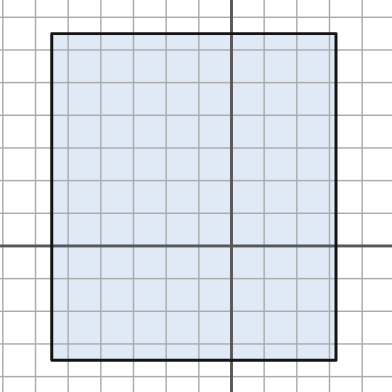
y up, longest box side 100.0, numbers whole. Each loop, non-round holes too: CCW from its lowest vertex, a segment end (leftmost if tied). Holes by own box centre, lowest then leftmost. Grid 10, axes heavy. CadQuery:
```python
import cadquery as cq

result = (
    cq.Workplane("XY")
    .moveTo(-55.0, -35.0)
    .lineTo(32.0, -35.0)
    .lineTo(32.0, 65.0)
    .lineTo(-55.0, 65.0)
    .close()
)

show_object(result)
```